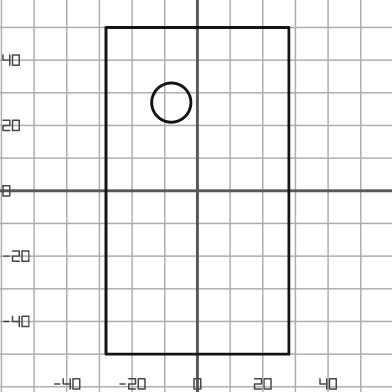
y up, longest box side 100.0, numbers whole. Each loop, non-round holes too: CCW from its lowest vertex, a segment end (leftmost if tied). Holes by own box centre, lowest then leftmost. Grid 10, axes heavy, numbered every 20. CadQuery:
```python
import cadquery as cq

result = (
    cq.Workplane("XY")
    .moveTo(-28.0, -50.0)
    .lineTo(28.0, -50.0)
    .lineTo(28.0, 50.0)
    .lineTo(-28.0, 50.0)
    .close()
    .moveTo(-8.0, 27.0)
    .circle(6.0)
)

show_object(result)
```